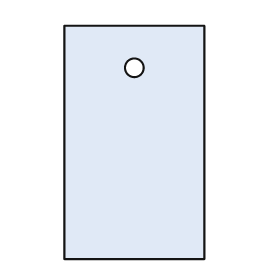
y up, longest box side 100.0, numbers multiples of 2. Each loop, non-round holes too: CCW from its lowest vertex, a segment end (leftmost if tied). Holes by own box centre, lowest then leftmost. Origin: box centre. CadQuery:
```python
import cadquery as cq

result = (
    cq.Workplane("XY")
    .moveTo(-30.0, -50.0)
    .lineTo(30.0, -50.0)
    .lineTo(30.0, 50.0)
    .lineTo(-30.0, 50.0)
    .close()
    .moveTo(0.0, 32.0)
    .circle(4.0)
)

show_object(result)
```